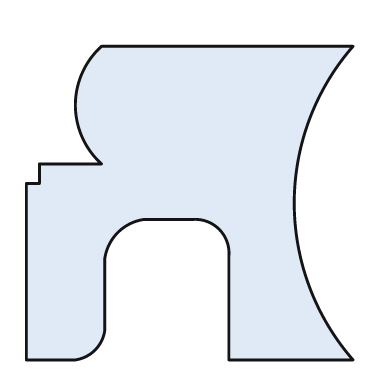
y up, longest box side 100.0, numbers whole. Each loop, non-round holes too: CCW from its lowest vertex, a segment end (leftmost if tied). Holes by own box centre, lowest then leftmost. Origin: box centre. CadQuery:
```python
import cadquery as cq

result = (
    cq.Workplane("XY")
    .moveTo(-50.0, -48.0)
    .lineTo(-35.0, -48.0)
    .threePointArc((-29.0, -45.0), (-26.0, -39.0))
    .lineTo(-26.0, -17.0)
    .threePointArc((-22.0, -9.0), (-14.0, -5.0))
    .lineTo(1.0, -5.0)
    .threePointArc((9.0, -8.0), (12.0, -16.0))
    .lineTo(12.0, -48.0)
    .lineTo(50.0, -48.0)
    .threePointArc((32.0, 0.0), (50.0, 48.0))
    .lineTo(-27.0, 48.0)
    .threePointArc((-35.0, 30.0), (-27.0, 12.0))
    .lineTo(-46.0, 12.0)
    .lineTo(-46.0, 6.0)
    .lineTo(-50.0, 6.0)
    .close()
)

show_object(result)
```